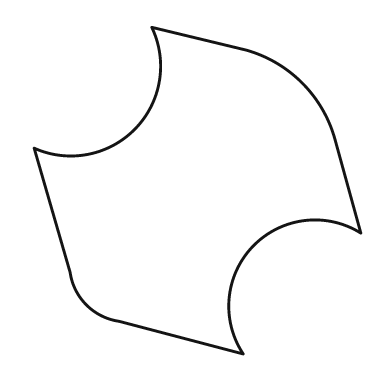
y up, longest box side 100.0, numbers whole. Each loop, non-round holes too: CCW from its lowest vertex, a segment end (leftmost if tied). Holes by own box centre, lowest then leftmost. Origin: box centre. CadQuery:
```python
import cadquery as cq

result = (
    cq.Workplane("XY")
    .moveTo(14.0, -50.0)
    .threePointArc((17.0, -17.0), (50.0, -13.0))
    .lineTo(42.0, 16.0)
    .threePointArc((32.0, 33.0), (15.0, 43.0))
    .lineTo(-14.0, 50.0)
    .threePointArc((-19.0, 19.0), (-50.0, 13.0))
    .lineTo(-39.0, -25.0)
    .threePointArc((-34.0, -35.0), (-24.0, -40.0))
    .close()
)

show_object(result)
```